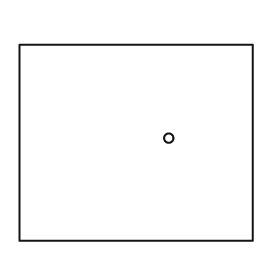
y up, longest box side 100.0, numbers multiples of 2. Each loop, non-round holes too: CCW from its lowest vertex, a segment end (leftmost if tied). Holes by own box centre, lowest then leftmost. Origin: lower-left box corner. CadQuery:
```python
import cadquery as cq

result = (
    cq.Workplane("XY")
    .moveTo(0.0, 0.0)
    .lineTo(100.0, 0.0)
    .lineTo(100.0, 84.0)
    .lineTo(0.0, 84.0)
    .close()
    .moveTo(64.0, 44.0)
    .circle(2.0)
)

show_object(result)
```